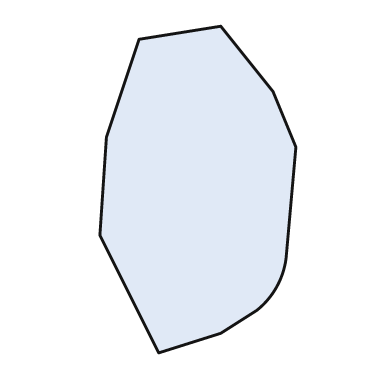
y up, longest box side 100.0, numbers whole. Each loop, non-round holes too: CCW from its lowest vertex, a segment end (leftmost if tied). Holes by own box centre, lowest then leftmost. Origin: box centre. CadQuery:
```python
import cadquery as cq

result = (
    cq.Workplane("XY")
    .moveTo(-12.0, -50.0)
    .lineTo(7.0, -44.0)
    .lineTo(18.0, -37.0)
    .threePointArc((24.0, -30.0), (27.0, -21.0))
    .lineTo(30.0, 13.0)
    .lineTo(23.0, 30.0)
    .lineTo(7.0, 50.0)
    .lineTo(-18.0, 46.0)
    .lineTo(-28.0, 16.0)
    .lineTo(-30.0, -14.0)
    .close()
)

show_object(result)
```